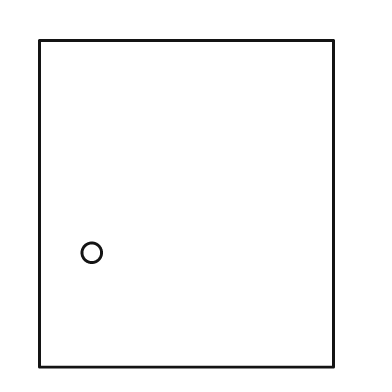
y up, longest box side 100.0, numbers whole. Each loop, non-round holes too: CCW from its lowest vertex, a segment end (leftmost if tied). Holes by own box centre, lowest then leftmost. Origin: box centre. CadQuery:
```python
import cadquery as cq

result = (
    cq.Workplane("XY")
    .moveTo(-45.0, -50.0)
    .lineTo(45.0, -50.0)
    .lineTo(45.0, 50.0)
    .lineTo(-45.0, 50.0)
    .close()
    .moveTo(-29.0, -15.0)
    .circle(3.0)
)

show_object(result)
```